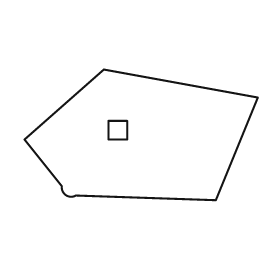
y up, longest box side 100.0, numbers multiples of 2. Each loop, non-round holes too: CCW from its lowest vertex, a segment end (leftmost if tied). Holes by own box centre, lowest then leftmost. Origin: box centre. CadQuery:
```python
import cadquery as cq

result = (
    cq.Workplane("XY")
    .moveTo(32.0, -28.0)
    .lineTo(50.0, 16.0)
    .lineTo(-16.0, 28.0)
    .lineTo(-50.0, -2.0)
    .lineTo(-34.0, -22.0)
    .threePointArc((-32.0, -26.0), (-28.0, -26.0))
    .close()
    .moveTo(-14.0, -2.0)
    .lineTo(-6.0, -2.0)
    .lineTo(-6.0, 6.0)
    .lineTo(-14.0, 6.0)
    .close()
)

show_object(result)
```